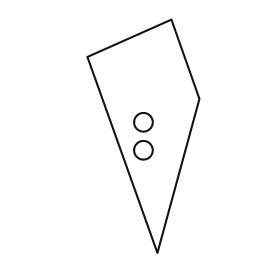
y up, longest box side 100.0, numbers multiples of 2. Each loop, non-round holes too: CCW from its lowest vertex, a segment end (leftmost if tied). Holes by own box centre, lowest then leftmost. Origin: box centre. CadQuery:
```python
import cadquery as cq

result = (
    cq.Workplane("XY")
    .moveTo(6.0, -50.0)
    .lineTo(24.0, 16.0)
    .lineTo(12.0, 50.0)
    .lineTo(-24.0, 34.0)
    .close()
    .moveTo(0.0, -6.0)
    .circle(4.0)
    .moveTo(0.0, 6.0)
    .circle(4.0)
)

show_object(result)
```